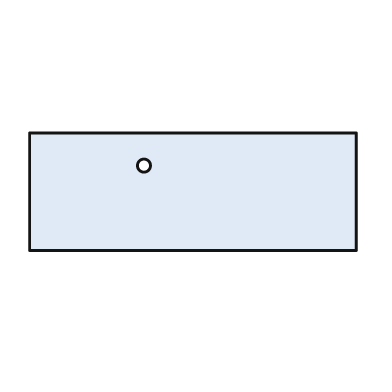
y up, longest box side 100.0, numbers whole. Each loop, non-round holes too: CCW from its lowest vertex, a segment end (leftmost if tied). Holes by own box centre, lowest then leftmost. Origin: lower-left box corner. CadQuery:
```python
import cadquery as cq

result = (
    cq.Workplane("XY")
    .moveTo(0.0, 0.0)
    .lineTo(100.0, 0.0)
    .lineTo(100.0, 36.0)
    .lineTo(0.0, 36.0)
    .close()
    .moveTo(35.0, 26.0)
    .circle(2.0)
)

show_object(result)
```